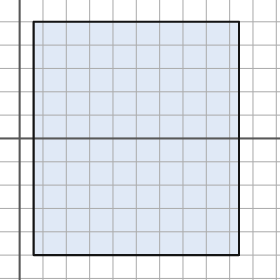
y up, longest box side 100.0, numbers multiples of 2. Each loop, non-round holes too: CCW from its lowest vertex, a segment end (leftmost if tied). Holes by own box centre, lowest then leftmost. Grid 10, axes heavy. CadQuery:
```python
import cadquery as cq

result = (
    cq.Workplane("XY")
    .moveTo(6.0, -50.0)
    .lineTo(94.0, -50.0)
    .lineTo(94.0, 50.0)
    .lineTo(6.0, 50.0)
    .close()
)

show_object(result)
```